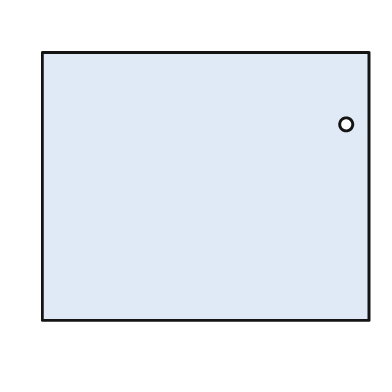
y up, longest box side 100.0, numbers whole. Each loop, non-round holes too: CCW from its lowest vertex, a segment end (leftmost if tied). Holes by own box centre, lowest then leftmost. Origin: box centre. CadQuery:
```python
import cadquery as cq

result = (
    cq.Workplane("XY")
    .moveTo(-50.0, -41.0)
    .lineTo(50.0, -41.0)
    .lineTo(50.0, 41.0)
    .lineTo(-50.0, 41.0)
    .close()
    .moveTo(43.0, 19.0)
    .circle(2.0)
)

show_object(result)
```